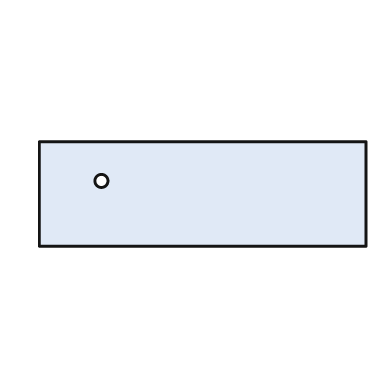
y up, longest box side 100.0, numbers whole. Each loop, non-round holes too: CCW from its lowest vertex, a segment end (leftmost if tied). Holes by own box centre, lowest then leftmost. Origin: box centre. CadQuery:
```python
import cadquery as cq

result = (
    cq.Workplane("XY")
    .moveTo(-50.0, -16.0)
    .lineTo(50.0, -16.0)
    .lineTo(50.0, 16.0)
    .lineTo(-50.0, 16.0)
    .close()
    .moveTo(-31.0, 4.0)
    .circle(2.0)
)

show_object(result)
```